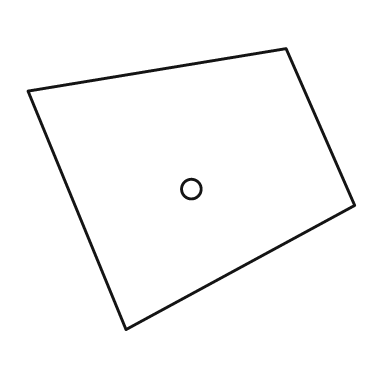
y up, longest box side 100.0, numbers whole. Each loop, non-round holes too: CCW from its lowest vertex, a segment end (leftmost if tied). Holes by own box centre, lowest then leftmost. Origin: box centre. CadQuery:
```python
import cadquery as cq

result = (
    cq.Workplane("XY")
    .moveTo(-20.0, -43.0)
    .lineTo(50.0, -5.0)
    .lineTo(29.0, 43.0)
    .lineTo(-50.0, 30.0)
    .close()
    .moveTo(0.0, 0.0)
    .circle(3.0)
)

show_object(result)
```